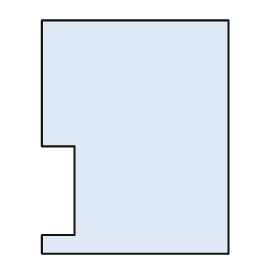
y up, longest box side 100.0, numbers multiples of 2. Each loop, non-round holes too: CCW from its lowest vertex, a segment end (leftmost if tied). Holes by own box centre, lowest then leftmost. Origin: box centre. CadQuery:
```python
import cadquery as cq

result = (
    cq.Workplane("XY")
    .moveTo(-40.0, -50.0)
    .lineTo(40.0, -50.0)
    .lineTo(40.0, 50.0)
    .lineTo(-40.0, 50.0)
    .lineTo(-40.0, -4.0)
    .lineTo(-26.0, -4.0)
    .lineTo(-26.0, -42.0)
    .lineTo(-40.0, -42.0)
    .close()
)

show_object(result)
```